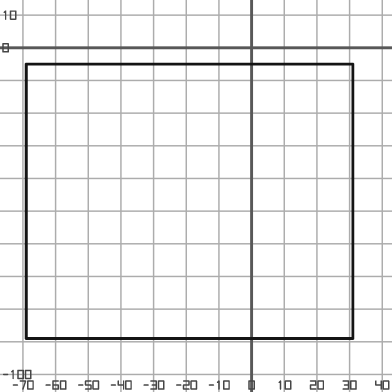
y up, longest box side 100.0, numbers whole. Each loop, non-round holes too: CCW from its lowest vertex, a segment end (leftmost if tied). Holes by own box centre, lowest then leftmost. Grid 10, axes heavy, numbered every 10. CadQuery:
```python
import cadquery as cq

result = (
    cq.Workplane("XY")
    .moveTo(-69.0, -89.0)
    .lineTo(31.0, -89.0)
    .lineTo(31.0, -5.0)
    .lineTo(-69.0, -5.0)
    .close()
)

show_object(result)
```